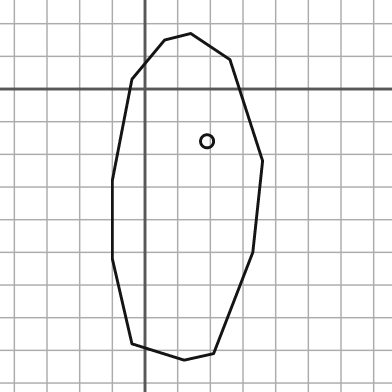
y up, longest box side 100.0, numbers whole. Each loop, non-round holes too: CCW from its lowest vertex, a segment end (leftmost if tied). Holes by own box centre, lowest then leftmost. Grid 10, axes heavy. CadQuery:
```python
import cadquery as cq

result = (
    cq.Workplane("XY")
    .moveTo(12.0, -83.0)
    .lineTo(21.0, -81.0)
    .lineTo(33.0, -50.0)
    .lineTo(36.0, -22.0)
    .lineTo(26.0, 9.0)
    .lineTo(14.0, 17.0)
    .lineTo(6.0, 15.0)
    .lineTo(-4.0, 3.0)
    .lineTo(-10.0, -28.0)
    .lineTo(-10.0, -52.0)
    .lineTo(-4.0, -78.0)
    .close()
    .moveTo(19.0, -16.0)
    .circle(2.0)
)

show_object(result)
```